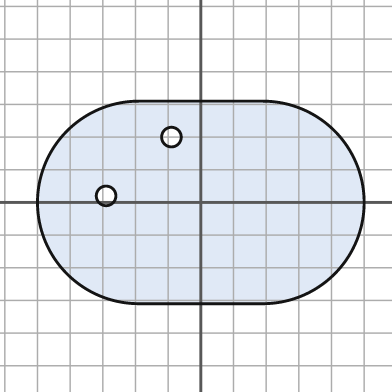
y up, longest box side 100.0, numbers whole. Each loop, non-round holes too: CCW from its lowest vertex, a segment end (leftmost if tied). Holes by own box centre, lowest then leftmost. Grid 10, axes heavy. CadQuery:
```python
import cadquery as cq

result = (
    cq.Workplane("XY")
    .moveTo(-19.0, -31.0)
    .lineTo(19.0, -31.0)
    .threePointArc((50.0, 0.0), (19.0, 31.0))
    .lineTo(-19.0, 31.0)
    .threePointArc((-50.0, 0.0), (-19.0, -31.0))
    .close()
    .moveTo(-29.0, 2.0)
    .circle(3.0)
    .moveTo(-9.0, 20.0)
    .circle(3.0)
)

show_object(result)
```